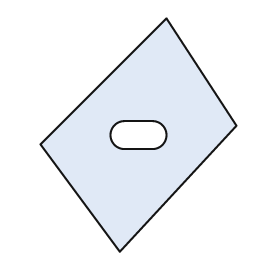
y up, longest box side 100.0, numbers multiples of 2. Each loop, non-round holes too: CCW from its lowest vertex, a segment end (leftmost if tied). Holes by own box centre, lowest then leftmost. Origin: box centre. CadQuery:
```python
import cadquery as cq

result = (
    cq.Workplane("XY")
    .moveTo(-8.0, -50.0)
    .lineTo(42.0, 4.0)
    .lineTo(12.0, 50.0)
    .lineTo(-42.0, -4.0)
    .close()
    .moveTo(-6.0, -6.0)
    .lineTo(6.0, -6.0)
    .threePointArc((12.0, 0.0), (6.0, 6.0))
    .lineTo(-6.0, 6.0)
    .threePointArc((-12.0, 0.0), (-6.0, -6.0))
    .close()
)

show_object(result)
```